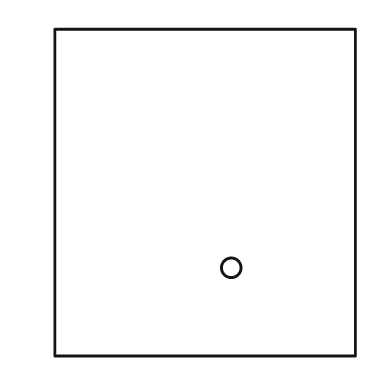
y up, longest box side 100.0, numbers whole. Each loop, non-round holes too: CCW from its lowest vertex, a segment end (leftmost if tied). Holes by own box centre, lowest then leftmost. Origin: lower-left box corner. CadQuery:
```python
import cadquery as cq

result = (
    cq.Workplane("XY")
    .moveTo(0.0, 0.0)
    .lineTo(92.0, 0.0)
    .lineTo(92.0, 100.0)
    .lineTo(0.0, 100.0)
    .close()
    .moveTo(54.0, 27.0)
    .circle(3.0)
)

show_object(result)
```